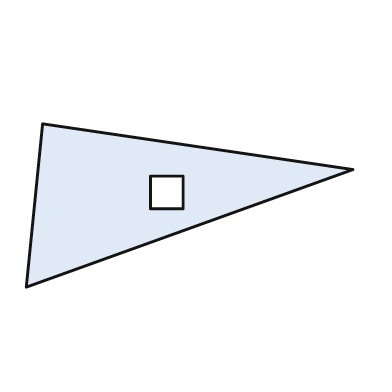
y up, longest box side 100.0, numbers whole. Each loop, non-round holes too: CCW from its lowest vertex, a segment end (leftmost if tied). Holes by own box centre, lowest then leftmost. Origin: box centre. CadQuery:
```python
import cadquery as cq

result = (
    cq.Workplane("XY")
    .moveTo(-50.0, -25.0)
    .lineTo(50.0, 11.0)
    .lineTo(-45.0, 25.0)
    .close()
    .moveTo(-12.0, -1.0)
    .lineTo(-2.0, -1.0)
    .lineTo(-2.0, 9.0)
    .lineTo(-12.0, 9.0)
    .close()
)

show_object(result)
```